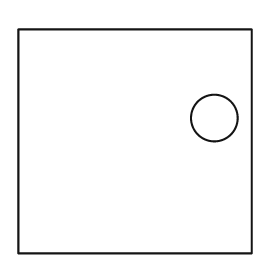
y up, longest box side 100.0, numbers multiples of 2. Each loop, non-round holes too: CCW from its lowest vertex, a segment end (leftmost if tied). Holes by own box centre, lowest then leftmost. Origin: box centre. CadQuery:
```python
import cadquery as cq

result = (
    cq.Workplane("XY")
    .moveTo(-50.0, -48.0)
    .lineTo(50.0, -48.0)
    .lineTo(50.0, 48.0)
    .lineTo(-50.0, 48.0)
    .close()
    .moveTo(34.0, 10.0)
    .circle(10.0)
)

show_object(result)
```